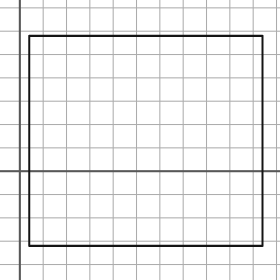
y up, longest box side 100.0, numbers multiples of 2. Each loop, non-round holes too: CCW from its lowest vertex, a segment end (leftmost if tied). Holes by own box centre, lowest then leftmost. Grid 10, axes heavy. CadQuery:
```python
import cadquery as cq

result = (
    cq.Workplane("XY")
    .moveTo(4.0, -32.0)
    .lineTo(104.0, -32.0)
    .lineTo(104.0, 58.0)
    .lineTo(4.0, 58.0)
    .close()
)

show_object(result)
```